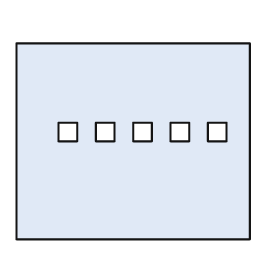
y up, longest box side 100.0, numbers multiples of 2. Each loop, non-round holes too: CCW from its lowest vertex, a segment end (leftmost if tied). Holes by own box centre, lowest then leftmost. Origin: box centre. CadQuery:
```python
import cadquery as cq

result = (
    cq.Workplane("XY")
    .moveTo(-50.0, -42.0)
    .lineTo(50.0, -42.0)
    .lineTo(50.0, 42.0)
    .lineTo(-50.0, 42.0)
    .close()
    .moveTo(-32.0, 0.0)
    .lineTo(-24.0, 0.0)
    .lineTo(-24.0, 8.0)
    .lineTo(-32.0, 8.0)
    .close()
    .moveTo(-16.0, 0.0)
    .lineTo(-8.0, 0.0)
    .lineTo(-8.0, 8.0)
    .lineTo(-16.0, 8.0)
    .close()
    .moveTo(0.0, 0.0)
    .lineTo(8.0, 0.0)
    .lineTo(8.0, 8.0)
    .lineTo(0.0, 8.0)
    .close()
    .moveTo(16.0, 0.0)
    .lineTo(24.0, 0.0)
    .lineTo(24.0, 8.0)
    .lineTo(16.0, 8.0)
    .close()
    .moveTo(32.0, 0.0)
    .lineTo(40.0, 0.0)
    .lineTo(40.0, 8.0)
    .lineTo(32.0, 8.0)
    .close()
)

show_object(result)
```